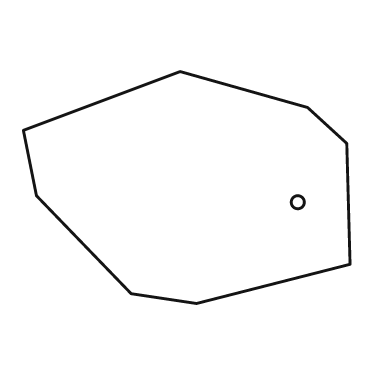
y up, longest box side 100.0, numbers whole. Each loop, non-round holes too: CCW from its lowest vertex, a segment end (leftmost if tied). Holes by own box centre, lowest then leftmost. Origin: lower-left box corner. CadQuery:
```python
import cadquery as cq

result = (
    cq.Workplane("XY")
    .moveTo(53.0, 0.0)
    .lineTo(100.0, 12.0)
    .lineTo(99.0, 49.0)
    .lineTo(87.0, 60.0)
    .lineTo(48.0, 71.0)
    .lineTo(0.0, 53.0)
    .lineTo(4.0, 33.0)
    .lineTo(33.0, 3.0)
    .close()
    .moveTo(84.0, 31.0)
    .circle(2.0)
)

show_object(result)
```